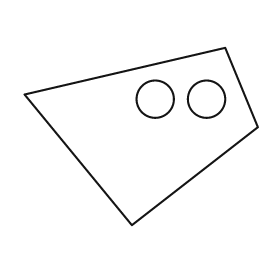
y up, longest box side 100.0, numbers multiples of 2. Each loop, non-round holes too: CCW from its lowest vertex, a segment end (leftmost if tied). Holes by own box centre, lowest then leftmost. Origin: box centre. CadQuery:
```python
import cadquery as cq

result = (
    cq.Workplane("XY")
    .moveTo(-4.0, -38.0)
    .lineTo(50.0, 4.0)
    .lineTo(36.0, 38.0)
    .lineTo(-50.0, 18.0)
    .close()
    .moveTo(6.0, 16.0)
    .circle(8.0)
    .moveTo(28.0, 16.0)
    .circle(8.0)
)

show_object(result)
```